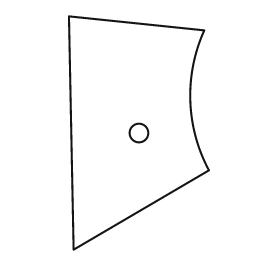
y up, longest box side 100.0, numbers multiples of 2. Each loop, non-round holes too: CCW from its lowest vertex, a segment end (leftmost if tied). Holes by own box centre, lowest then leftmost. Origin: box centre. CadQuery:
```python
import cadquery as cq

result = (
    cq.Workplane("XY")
    .moveTo(-28.0, -50.0)
    .lineTo(30.0, -16.0)
    .threePointArc((22.0, 14.0), (28.0, 44.0))
    .lineTo(-30.0, 50.0)
    .close()
    .moveTo(0.0, 0.0)
    .circle(4.0)
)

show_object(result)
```